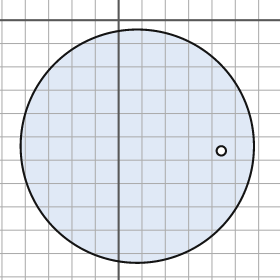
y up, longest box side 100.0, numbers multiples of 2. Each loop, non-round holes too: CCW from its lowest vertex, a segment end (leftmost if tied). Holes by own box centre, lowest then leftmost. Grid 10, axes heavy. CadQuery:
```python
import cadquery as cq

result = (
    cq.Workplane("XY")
    .moveTo(8.0, -54.0)
    .circle(50.0)
    .moveTo(44.0, -56.0)
    .circle(2.0)
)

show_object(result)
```